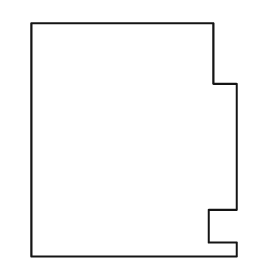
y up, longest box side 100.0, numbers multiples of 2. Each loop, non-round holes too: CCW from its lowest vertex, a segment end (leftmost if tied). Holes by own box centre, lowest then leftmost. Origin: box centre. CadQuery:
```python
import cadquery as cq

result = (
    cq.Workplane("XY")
    .moveTo(-44.0, -50.0)
    .lineTo(44.0, -50.0)
    .lineTo(44.0, -44.0)
    .lineTo(32.0, -44.0)
    .lineTo(32.0, -30.0)
    .lineTo(44.0, -30.0)
    .lineTo(44.0, 24.0)
    .lineTo(34.0, 24.0)
    .lineTo(34.0, 50.0)
    .lineTo(-44.0, 50.0)
    .close()
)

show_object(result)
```